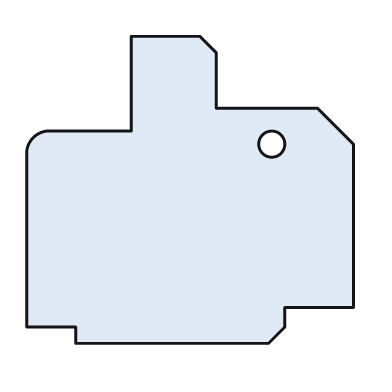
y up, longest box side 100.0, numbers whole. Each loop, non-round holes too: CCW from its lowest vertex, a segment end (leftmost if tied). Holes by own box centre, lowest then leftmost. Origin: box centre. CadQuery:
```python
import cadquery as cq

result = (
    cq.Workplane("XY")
    .moveTo(-35.0, -47.0)
    .lineTo(24.0, -47.0)
    .lineTo(29.0, -42.0)
    .lineTo(29.0, -36.0)
    .lineTo(50.0, -36.0)
    .lineTo(50.0, 14.0)
    .lineTo(39.0, 25.0)
    .lineTo(8.0, 25.0)
    .lineTo(8.0, 42.0)
    .lineTo(3.0, 47.0)
    .lineTo(-18.0, 47.0)
    .lineTo(-18.0, 18.0)
    .lineTo(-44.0, 18.0)
    .threePointArc((-48.0, 16.0), (-50.0, 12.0))
    .lineTo(-50.0, -42.0)
    .lineTo(-35.0, -42.0)
    .close()
    .moveTo(25.0, 14.0)
    .circle(4.0)
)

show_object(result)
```